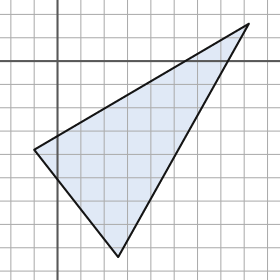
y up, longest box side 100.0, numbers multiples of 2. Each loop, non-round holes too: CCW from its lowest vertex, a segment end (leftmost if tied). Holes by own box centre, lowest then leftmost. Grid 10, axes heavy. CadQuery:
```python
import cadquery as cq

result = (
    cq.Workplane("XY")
    .moveTo(26.0, -84.0)
    .lineTo(82.0, 16.0)
    .lineTo(-10.0, -38.0)
    .close()
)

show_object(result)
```